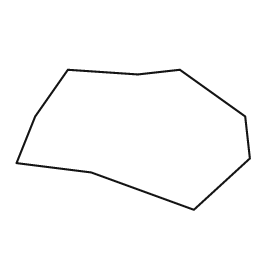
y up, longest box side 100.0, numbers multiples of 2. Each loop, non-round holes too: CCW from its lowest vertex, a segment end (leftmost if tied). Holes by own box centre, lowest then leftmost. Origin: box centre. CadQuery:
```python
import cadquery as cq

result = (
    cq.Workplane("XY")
    .moveTo(26.0, -30.0)
    .lineTo(50.0, -8.0)
    .lineTo(48.0, 10.0)
    .lineTo(20.0, 30.0)
    .lineTo(2.0, 28.0)
    .lineTo(-28.0, 30.0)
    .lineTo(-42.0, 10.0)
    .lineTo(-50.0, -10.0)
    .lineTo(-18.0, -14.0)
    .close()
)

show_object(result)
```